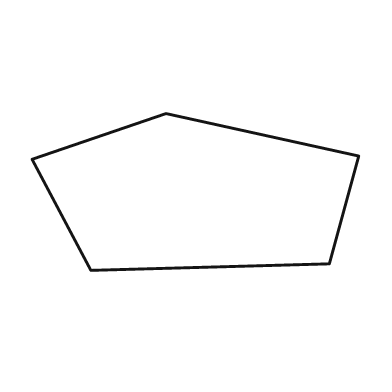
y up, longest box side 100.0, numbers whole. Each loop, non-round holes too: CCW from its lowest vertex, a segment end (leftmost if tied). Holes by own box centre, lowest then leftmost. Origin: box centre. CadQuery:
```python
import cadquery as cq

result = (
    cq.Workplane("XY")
    .moveTo(-32.0, -24.0)
    .lineTo(41.0, -22.0)
    .lineTo(50.0, 11.0)
    .lineTo(-9.0, 24.0)
    .lineTo(-50.0, 10.0)
    .close()
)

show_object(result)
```